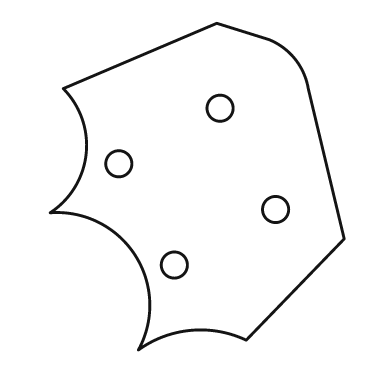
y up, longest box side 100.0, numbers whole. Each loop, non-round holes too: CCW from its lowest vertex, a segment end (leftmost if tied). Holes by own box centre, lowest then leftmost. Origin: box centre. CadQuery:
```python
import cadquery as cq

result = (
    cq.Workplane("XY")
    .moveTo(-18.0, -50.0)
    .threePointArc((-2.0, -44.0), (15.0, -47.0))
    .lineTo(45.0, -16.0)
    .lineTo(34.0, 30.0)
    .threePointArc((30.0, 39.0), (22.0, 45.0))
    .lineTo(6.0, 50.0)
    .lineTo(-41.0, 30.0)
    .threePointArc((-34.0, 10.0), (-45.0, -8.0))
    .threePointArc((-19.0, -21.0), (-18.0, -50.0))
    .close()
    .moveTo(-7.0, -24.0)
    .circle(4.0)
    .moveTo(24.0, -7.0)
    .circle(4.0)
    .moveTo(-24.0, 7.0)
    .circle(4.0)
    .moveTo(7.0, 24.0)
    .circle(4.0)
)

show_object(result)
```